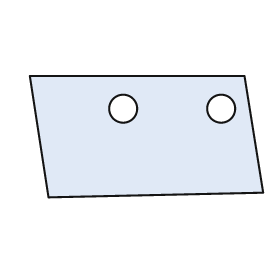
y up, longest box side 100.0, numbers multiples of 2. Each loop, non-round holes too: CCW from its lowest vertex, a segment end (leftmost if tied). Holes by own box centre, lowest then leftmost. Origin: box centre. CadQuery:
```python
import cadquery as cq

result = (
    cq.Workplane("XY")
    .moveTo(-42.0, -26.0)
    .lineTo(50.0, -24.0)
    .lineTo(42.0, 26.0)
    .lineTo(-50.0, 26.0)
    .close()
    .moveTo(-10.0, 12.0)
    .circle(6.0)
    .moveTo(32.0, 12.0)
    .circle(6.0)
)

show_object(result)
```